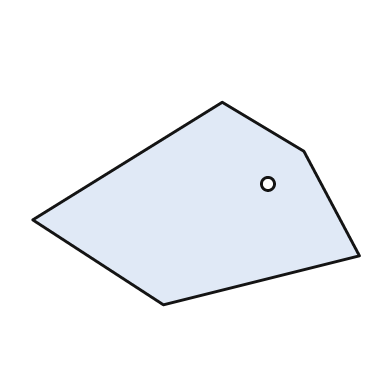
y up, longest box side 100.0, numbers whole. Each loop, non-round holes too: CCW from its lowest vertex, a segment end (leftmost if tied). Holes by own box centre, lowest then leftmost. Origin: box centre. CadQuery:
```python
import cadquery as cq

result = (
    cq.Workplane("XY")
    .moveTo(-10.0, -31.0)
    .lineTo(50.0, -16.0)
    .lineTo(33.0, 16.0)
    .lineTo(8.0, 31.0)
    .lineTo(-50.0, -5.0)
    .close()
    .moveTo(22.0, 6.0)
    .circle(2.0)
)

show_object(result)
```